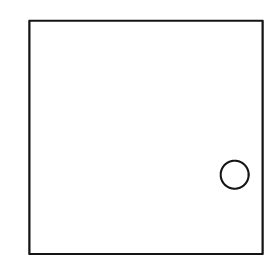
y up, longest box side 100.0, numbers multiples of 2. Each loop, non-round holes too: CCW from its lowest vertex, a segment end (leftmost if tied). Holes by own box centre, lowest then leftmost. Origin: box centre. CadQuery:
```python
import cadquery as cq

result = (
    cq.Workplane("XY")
    .moveTo(-50.0, -50.0)
    .lineTo(50.0, -50.0)
    .lineTo(50.0, 50.0)
    .lineTo(-50.0, 50.0)
    .close()
    .moveTo(38.0, -16.0)
    .circle(6.0)
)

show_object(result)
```